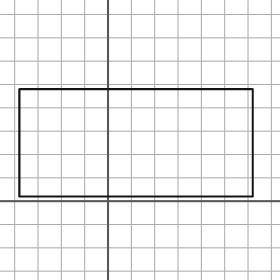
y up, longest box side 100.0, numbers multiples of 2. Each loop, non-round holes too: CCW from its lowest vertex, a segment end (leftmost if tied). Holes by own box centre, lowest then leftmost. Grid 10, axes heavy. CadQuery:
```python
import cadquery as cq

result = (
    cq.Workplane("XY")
    .moveTo(-38.0, 2.0)
    .lineTo(62.0, 2.0)
    .lineTo(62.0, 48.0)
    .lineTo(-38.0, 48.0)
    .close()
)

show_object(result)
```